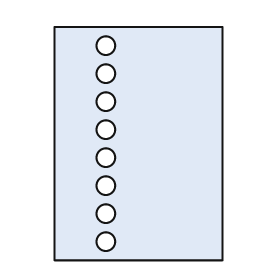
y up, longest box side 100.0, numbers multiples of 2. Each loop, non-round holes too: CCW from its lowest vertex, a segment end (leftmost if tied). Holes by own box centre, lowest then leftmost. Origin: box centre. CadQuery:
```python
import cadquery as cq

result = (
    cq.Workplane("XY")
    .moveTo(-36.0, -50.0)
    .lineTo(36.0, -50.0)
    .lineTo(36.0, 50.0)
    .lineTo(-36.0, 50.0)
    .close()
    .moveTo(-14.0, -42.0)
    .circle(4.0)
    .moveTo(-14.0, -30.0)
    .circle(4.0)
    .moveTo(-14.0, -18.0)
    .circle(4.0)
    .moveTo(-14.0, -6.0)
    .circle(4.0)
    .moveTo(-14.0, 6.0)
    .circle(4.0)
    .moveTo(-14.0, 18.0)
    .circle(4.0)
    .moveTo(-14.0, 30.0)
    .circle(4.0)
    .moveTo(-14.0, 42.0)
    .circle(4.0)
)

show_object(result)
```